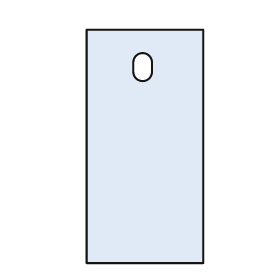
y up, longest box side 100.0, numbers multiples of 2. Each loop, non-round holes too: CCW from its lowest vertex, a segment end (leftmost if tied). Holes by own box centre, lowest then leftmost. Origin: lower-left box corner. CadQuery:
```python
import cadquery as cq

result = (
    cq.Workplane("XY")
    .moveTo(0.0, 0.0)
    .lineTo(50.0, 0.0)
    .lineTo(50.0, 100.0)
    .lineTo(0.0, 100.0)
    .close()
    .moveTo(20.0, 82.0)
    .threePointArc((24.0, 78.0), (28.0, 82.0))
    .lineTo(28.0, 86.0)
    .threePointArc((24.0, 90.0), (20.0, 86.0))
    .close()
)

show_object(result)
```